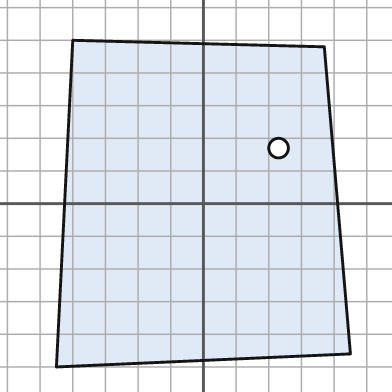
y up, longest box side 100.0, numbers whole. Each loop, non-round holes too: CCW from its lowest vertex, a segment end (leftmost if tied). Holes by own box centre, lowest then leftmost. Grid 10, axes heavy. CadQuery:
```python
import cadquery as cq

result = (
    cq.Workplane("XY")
    .moveTo(-45.0, -50.0)
    .lineTo(45.0, -46.0)
    .lineTo(37.0, 48.0)
    .lineTo(-40.0, 50.0)
    .close()
    .moveTo(23.0, 17.0)
    .circle(3.0)
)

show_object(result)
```